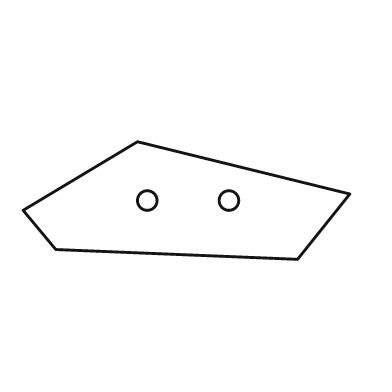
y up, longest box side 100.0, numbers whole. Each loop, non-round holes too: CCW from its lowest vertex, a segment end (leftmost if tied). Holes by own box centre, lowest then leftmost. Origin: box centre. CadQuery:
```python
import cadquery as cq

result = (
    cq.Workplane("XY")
    .moveTo(34.0, -18.0)
    .lineTo(50.0, 2.0)
    .lineTo(-15.0, 18.0)
    .lineTo(-50.0, -3.0)
    .lineTo(-40.0, -15.0)
    .close()
    .moveTo(-12.0, 0.0)
    .circle(3.0)
    .moveTo(13.0, 0.0)
    .circle(3.0)
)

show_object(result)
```